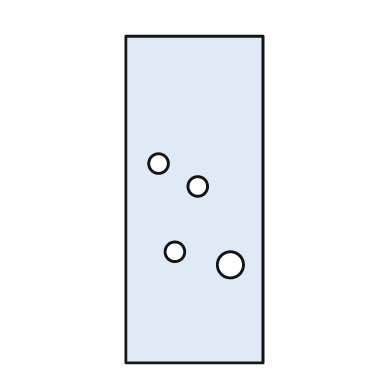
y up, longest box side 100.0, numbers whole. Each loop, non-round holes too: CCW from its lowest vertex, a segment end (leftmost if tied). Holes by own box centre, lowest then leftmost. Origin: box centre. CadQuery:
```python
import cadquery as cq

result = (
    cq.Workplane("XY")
    .moveTo(-21.0, -50.0)
    .lineTo(21.0, -50.0)
    .lineTo(21.0, 50.0)
    .lineTo(-21.0, 50.0)
    .close()
    .moveTo(11.0, -20.0)
    .circle(4.0)
    .moveTo(-6.0, -16.0)
    .circle(3.0)
    .moveTo(1.0, 4.0)
    .circle(3.0)
    .moveTo(-11.0, 11.0)
    .circle(3.0)
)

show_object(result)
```